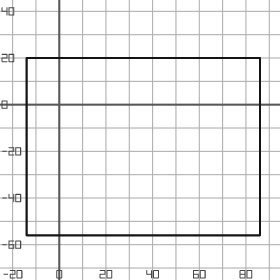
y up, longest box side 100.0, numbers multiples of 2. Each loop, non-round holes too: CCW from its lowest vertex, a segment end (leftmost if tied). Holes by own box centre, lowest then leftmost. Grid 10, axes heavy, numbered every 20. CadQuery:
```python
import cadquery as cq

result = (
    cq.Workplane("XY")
    .moveTo(-14.0, -56.0)
    .lineTo(86.0, -56.0)
    .lineTo(86.0, 20.0)
    .lineTo(-14.0, 20.0)
    .close()
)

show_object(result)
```